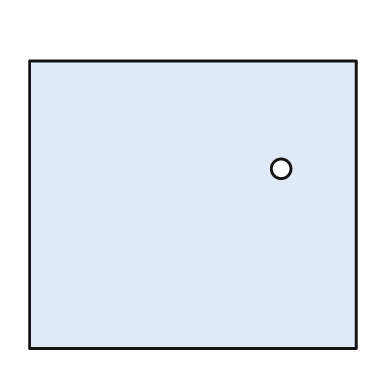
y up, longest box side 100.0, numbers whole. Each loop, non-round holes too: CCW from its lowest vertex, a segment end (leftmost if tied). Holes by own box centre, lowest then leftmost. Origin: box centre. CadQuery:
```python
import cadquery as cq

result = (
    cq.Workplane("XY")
    .moveTo(-50.0, -44.0)
    .lineTo(50.0, -44.0)
    .lineTo(50.0, 44.0)
    .lineTo(-50.0, 44.0)
    .close()
    .moveTo(27.0, 11.0)
    .circle(3.0)
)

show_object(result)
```